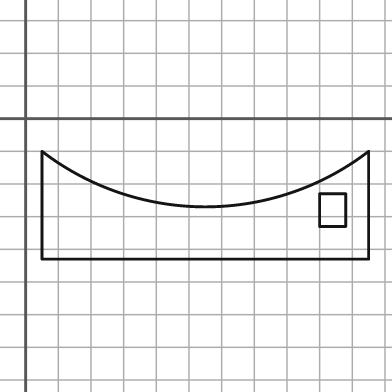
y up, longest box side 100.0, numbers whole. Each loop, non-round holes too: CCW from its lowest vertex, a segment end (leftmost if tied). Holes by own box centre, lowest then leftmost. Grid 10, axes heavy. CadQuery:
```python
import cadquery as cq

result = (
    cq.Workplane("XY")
    .moveTo(5.0, -43.0)
    .lineTo(105.0, -43.0)
    .lineTo(105.0, -10.0)
    .threePointArc((55.0, -27.0), (5.0, -10.0))
    .close()
    .moveTo(90.0, -33.0)
    .lineTo(98.0, -33.0)
    .lineTo(98.0, -23.0)
    .lineTo(90.0, -23.0)
    .close()
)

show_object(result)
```